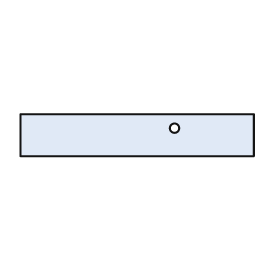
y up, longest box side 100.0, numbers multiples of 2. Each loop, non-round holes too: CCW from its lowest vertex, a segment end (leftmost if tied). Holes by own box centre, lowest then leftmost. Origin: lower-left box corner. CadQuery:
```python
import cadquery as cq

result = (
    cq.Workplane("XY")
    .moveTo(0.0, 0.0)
    .lineTo(100.0, 0.0)
    .lineTo(100.0, 18.0)
    .lineTo(0.0, 18.0)
    .close()
    .moveTo(66.0, 12.0)
    .circle(2.0)
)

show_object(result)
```